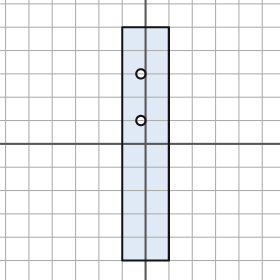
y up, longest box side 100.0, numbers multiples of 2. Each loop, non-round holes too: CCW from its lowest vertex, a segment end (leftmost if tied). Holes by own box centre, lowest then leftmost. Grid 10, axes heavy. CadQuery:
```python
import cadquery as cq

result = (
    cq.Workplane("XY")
    .moveTo(-10.0, -50.0)
    .lineTo(10.0, -50.0)
    .lineTo(10.0, 50.0)
    .lineTo(-10.0, 50.0)
    .close()
    .moveTo(-2.0, 10.0)
    .circle(2.0)
    .moveTo(-2.0, 30.0)
    .circle(2.0)
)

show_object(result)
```